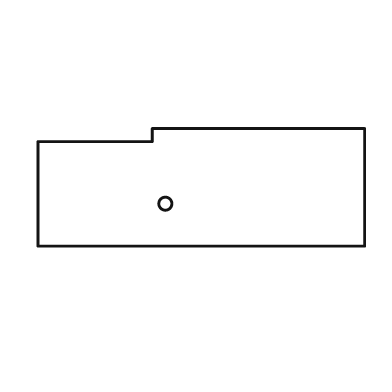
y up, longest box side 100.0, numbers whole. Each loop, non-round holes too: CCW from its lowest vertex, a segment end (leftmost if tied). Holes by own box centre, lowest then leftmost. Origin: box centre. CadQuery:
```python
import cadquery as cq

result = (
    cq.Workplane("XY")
    .moveTo(-50.0, -18.0)
    .lineTo(50.0, -18.0)
    .lineTo(50.0, 18.0)
    .lineTo(-15.0, 18.0)
    .lineTo(-15.0, 14.0)
    .lineTo(-50.0, 14.0)
    .close()
    .moveTo(-11.0, -5.0)
    .circle(2.0)
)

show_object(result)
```